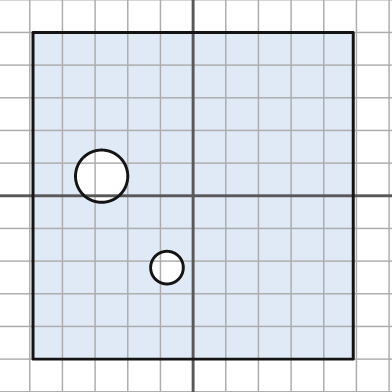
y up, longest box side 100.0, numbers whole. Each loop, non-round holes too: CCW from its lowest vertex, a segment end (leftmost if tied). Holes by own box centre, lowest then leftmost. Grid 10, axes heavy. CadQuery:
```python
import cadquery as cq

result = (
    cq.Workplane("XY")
    .moveTo(-49.0, -50.0)
    .lineTo(49.0, -50.0)
    .lineTo(49.0, 50.0)
    .lineTo(-49.0, 50.0)
    .close()
    .moveTo(-8.0, -22.0)
    .circle(5.0)
    .moveTo(-28.0, 6.0)
    .circle(8.0)
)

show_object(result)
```